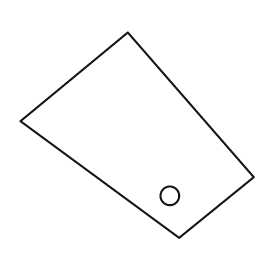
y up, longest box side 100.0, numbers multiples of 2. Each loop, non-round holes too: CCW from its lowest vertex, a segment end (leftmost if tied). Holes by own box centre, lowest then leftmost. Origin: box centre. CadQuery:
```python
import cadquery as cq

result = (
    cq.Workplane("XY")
    .moveTo(18.0, -44.0)
    .lineTo(50.0, -18.0)
    .lineTo(-4.0, 44.0)
    .lineTo(-50.0, 6.0)
    .close()
    .moveTo(14.0, -26.0)
    .circle(4.0)
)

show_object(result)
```